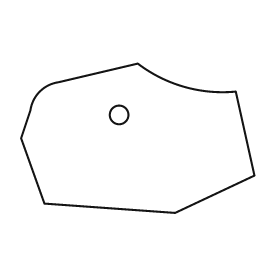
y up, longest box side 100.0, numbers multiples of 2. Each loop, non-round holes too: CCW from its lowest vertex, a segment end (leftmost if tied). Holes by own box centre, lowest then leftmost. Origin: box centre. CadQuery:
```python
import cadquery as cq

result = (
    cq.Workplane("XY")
    .moveTo(16.0, -32.0)
    .lineTo(50.0, -16.0)
    .lineTo(42.0, 20.0)
    .threePointArc((20.0, 22.0), (0.0, 32.0))
    .lineTo(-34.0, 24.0)
    .threePointArc((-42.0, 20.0), (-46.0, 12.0))
    .lineTo(-50.0, 0.0)
    .lineTo(-40.0, -28.0)
    .close()
    .moveTo(-8.0, 10.0)
    .circle(4.0)
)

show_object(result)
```